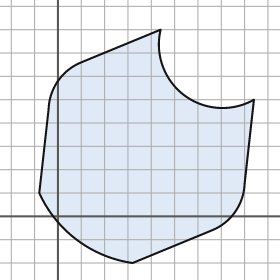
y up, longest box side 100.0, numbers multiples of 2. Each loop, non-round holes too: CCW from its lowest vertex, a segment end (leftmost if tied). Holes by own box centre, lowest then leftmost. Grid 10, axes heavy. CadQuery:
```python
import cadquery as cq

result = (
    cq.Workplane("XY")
    .moveTo(32.0, -20.0)
    .lineTo(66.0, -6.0)
    .threePointArc((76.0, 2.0), (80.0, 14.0))
    .lineTo(84.0, 50.0)
    .threePointArc((54.0, 52.0), (44.0, 80.0))
    .lineTo(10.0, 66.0)
    .threePointArc((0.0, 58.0), (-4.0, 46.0))
    .lineTo(-8.0, 10.0)
    .threePointArc((8.0, -10.0), (32.0, -20.0))
    .close()
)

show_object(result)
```